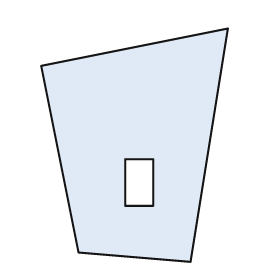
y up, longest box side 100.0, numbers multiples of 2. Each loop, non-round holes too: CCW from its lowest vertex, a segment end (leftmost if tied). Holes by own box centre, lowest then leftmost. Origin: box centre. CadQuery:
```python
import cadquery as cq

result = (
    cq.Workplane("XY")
    .moveTo(24.0, -50.0)
    .lineTo(40.0, 50.0)
    .lineTo(-40.0, 34.0)
    .lineTo(-24.0, -46.0)
    .close()
    .moveTo(-4.0, -26.0)
    .lineTo(8.0, -26.0)
    .lineTo(8.0, -6.0)
    .lineTo(-4.0, -6.0)
    .close()
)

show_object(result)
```